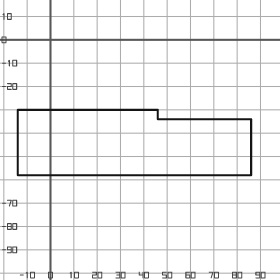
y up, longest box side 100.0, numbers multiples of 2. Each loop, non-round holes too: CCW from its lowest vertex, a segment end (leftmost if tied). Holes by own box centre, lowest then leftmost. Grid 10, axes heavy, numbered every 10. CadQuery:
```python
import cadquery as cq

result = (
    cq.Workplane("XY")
    .moveTo(-14.0, -58.0)
    .lineTo(86.0, -58.0)
    .lineTo(86.0, -34.0)
    .lineTo(46.0, -34.0)
    .lineTo(46.0, -30.0)
    .lineTo(-14.0, -30.0)
    .close()
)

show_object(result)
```